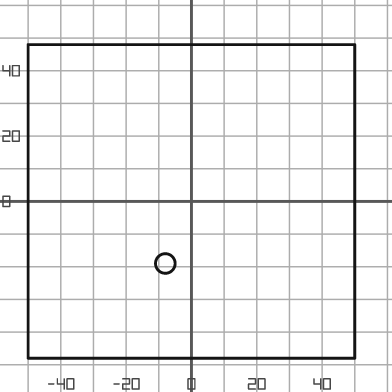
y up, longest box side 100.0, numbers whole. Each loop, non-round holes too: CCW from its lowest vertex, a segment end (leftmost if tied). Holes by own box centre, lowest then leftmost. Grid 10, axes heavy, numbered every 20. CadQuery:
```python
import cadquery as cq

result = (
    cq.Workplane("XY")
    .moveTo(-50.0, -48.0)
    .lineTo(50.0, -48.0)
    .lineTo(50.0, 48.0)
    .lineTo(-50.0, 48.0)
    .close()
    .moveTo(-8.0, -19.0)
    .circle(3.0)
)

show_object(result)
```